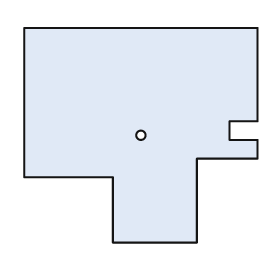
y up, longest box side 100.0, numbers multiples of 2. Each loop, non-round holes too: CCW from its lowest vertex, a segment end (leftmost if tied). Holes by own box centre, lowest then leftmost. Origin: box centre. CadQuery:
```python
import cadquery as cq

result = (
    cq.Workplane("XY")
    .moveTo(-12.0, -46.0)
    .lineTo(24.0, -46.0)
    .lineTo(24.0, -10.0)
    .lineTo(50.0, -10.0)
    .lineTo(50.0, -2.0)
    .lineTo(38.0, -2.0)
    .lineTo(38.0, 6.0)
    .lineTo(50.0, 6.0)
    .lineTo(50.0, 46.0)
    .lineTo(-50.0, 46.0)
    .lineTo(-50.0, -18.0)
    .lineTo(-12.0, -18.0)
    .close()
    .moveTo(0.0, 0.0)
    .circle(2.0)
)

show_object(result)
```